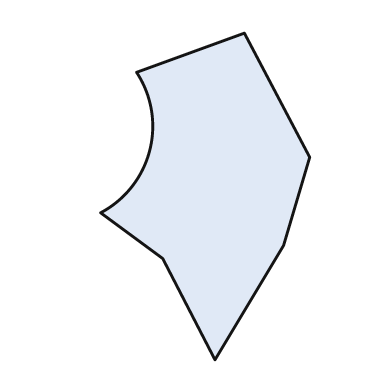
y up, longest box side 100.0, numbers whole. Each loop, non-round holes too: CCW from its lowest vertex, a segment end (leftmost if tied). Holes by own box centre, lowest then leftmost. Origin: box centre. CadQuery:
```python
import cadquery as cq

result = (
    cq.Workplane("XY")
    .moveTo(3.0, -50.0)
    .lineTo(24.0, -15.0)
    .lineTo(32.0, 12.0)
    .lineTo(12.0, 50.0)
    .lineTo(-21.0, 38.0)
    .threePointArc((-17.0, 14.0), (-32.0, -5.0))
    .lineTo(-13.0, -19.0)
    .close()
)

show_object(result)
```